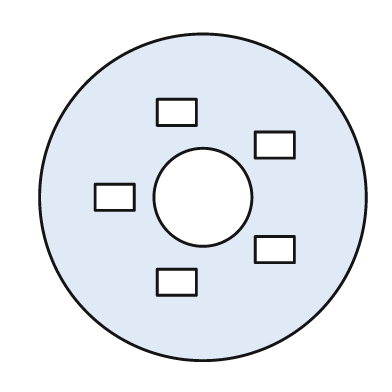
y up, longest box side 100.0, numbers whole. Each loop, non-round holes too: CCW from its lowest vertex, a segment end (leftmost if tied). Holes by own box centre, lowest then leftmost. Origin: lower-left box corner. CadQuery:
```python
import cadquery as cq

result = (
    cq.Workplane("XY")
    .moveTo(50.0, 50.0)
    .circle(50.0)
    .moveTo(36.0, 20.0)
    .lineTo(48.0, 20.0)
    .lineTo(48.0, 28.0)
    .lineTo(36.0, 28.0)
    .close()
    .moveTo(66.0, 30.0)
    .lineTo(78.0, 30.0)
    .lineTo(78.0, 38.0)
    .lineTo(66.0, 38.0)
    .close()
    .moveTo(17.0, 46.0)
    .lineTo(29.0, 46.0)
    .lineTo(29.0, 54.0)
    .lineTo(17.0, 54.0)
    .close()
    .moveTo(50.0, 50.0)
    .circle(15.0)
    .moveTo(66.0, 62.0)
    .lineTo(78.0, 62.0)
    .lineTo(78.0, 70.0)
    .lineTo(66.0, 70.0)
    .close()
    .moveTo(36.0, 72.0)
    .lineTo(48.0, 72.0)
    .lineTo(48.0, 80.0)
    .lineTo(36.0, 80.0)
    .close()
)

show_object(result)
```